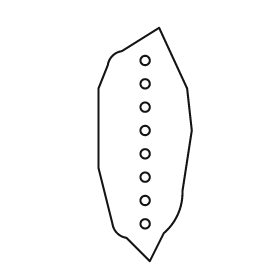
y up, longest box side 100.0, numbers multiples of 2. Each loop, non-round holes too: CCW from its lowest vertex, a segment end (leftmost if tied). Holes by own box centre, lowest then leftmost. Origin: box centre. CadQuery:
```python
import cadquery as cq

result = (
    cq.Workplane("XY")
    .moveTo(2.0, -50.0)
    .lineTo(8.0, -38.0)
    .threePointArc((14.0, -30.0), (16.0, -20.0))
    .lineTo(20.0, 6.0)
    .lineTo(18.0, 24.0)
    .lineTo(6.0, 50.0)
    .lineTo(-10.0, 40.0)
    .threePointArc((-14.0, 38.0), (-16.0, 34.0))
    .lineTo(-20.0, 24.0)
    .lineTo(-20.0, -10.0)
    .lineTo(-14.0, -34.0)
    .threePointArc((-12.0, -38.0), (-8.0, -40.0))
    .close()
    .moveTo(0.0, -34.0)
    .circle(2.0)
    .moveTo(0.0, -24.0)
    .circle(2.0)
    .moveTo(0.0, -14.0)
    .circle(2.0)
    .moveTo(0.0, -4.0)
    .circle(2.0)
    .moveTo(0.0, 6.0)
    .circle(2.0)
    .moveTo(0.0, 16.0)
    .circle(2.0)
    .moveTo(0.0, 26.0)
    .circle(2.0)
    .moveTo(0.0, 36.0)
    .circle(2.0)
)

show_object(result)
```